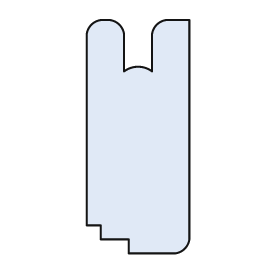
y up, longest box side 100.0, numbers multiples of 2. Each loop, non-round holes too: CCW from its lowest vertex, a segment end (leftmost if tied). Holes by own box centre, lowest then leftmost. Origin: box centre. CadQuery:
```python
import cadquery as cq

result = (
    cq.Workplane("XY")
    .moveTo(-4.0, -50.0)
    .lineTo(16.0, -50.0)
    .threePointArc((20.0, -48.0), (22.0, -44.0))
    .lineTo(22.0, 50.0)
    .lineTo(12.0, 50.0)
    .threePointArc((8.0, 48.0), (6.0, 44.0))
    .lineTo(6.0, 28.0)
    .threePointArc((0.0, 30.0), (-6.0, 28.0))
    .lineTo(-6.0, 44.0)
    .threePointArc((-8.0, 48.0), (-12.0, 50.0))
    .lineTo(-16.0, 50.0)
    .threePointArc((-20.0, 48.0), (-22.0, 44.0))
    .lineTo(-22.0, -38.0)
    .lineTo(-16.0, -38.0)
    .lineTo(-16.0, -44.0)
    .lineTo(-4.0, -44.0)
    .close()
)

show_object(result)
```